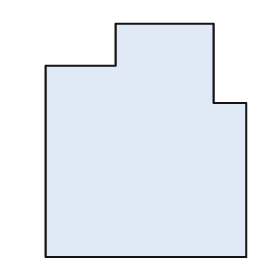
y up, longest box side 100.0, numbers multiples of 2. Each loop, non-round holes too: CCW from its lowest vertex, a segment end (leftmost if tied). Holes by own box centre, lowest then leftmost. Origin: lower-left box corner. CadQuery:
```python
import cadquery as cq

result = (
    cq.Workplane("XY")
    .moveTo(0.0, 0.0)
    .lineTo(86.0, 0.0)
    .lineTo(86.0, 66.0)
    .lineTo(72.0, 66.0)
    .lineTo(72.0, 100.0)
    .lineTo(30.0, 100.0)
    .lineTo(30.0, 82.0)
    .lineTo(0.0, 82.0)
    .close()
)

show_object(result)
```